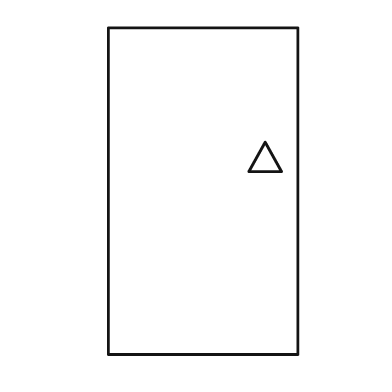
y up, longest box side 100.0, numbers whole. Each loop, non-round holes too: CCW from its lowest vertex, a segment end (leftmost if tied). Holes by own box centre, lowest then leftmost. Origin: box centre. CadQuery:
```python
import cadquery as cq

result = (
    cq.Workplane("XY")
    .moveTo(-29.0, -50.0)
    .lineTo(29.0, -50.0)
    .lineTo(29.0, 50.0)
    .lineTo(-29.0, 50.0)
    .close()
    .moveTo(14.0, 6.0)
    .lineTo(24.0, 6.0)
    .lineTo(19.0, 15.0)
    .close()
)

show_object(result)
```